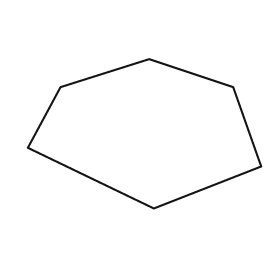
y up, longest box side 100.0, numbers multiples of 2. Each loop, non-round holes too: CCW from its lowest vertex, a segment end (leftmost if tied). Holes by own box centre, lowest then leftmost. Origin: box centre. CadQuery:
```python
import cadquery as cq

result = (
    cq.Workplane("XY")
    .moveTo(4.0, -32.0)
    .lineTo(50.0, -14.0)
    .lineTo(38.0, 20.0)
    .lineTo(2.0, 32.0)
    .lineTo(-36.0, 20.0)
    .lineTo(-50.0, -6.0)
    .close()
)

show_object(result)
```